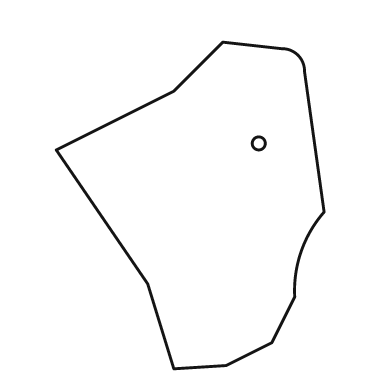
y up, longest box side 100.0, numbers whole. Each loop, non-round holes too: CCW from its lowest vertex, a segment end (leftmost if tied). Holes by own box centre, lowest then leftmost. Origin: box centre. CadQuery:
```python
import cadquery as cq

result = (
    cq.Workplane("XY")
    .moveTo(-5.0, -50.0)
    .lineTo(11.0, -49.0)
    .lineTo(25.0, -42.0)
    .lineTo(32.0, -28.0)
    .threePointArc((34.0, -14.0), (41.0, -2.0))
    .lineTo(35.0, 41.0)
    .threePointArc((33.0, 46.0), (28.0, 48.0))
    .lineTo(10.0, 50.0)
    .lineTo(-5.0, 35.0)
    .lineTo(-41.0, 17.0)
    .lineTo(-13.0, -24.0)
    .close()
    .moveTo(21.0, 19.0)
    .circle(2.0)
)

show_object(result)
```